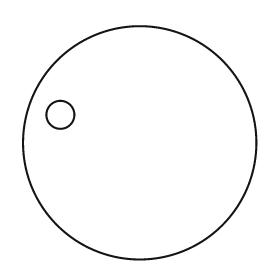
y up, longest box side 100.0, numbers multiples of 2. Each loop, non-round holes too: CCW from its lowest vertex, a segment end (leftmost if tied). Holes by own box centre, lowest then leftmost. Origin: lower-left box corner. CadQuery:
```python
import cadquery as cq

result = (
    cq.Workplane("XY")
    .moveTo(50.0, 50.0)
    .circle(50.0)
    .moveTo(16.0, 62.0)
    .circle(6.0)
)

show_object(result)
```